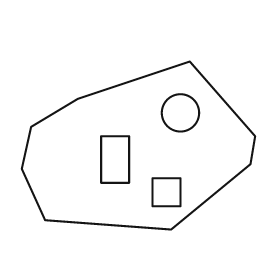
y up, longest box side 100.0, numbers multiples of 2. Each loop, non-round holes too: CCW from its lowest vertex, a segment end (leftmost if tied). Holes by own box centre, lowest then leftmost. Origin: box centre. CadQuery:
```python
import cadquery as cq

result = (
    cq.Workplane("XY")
    .moveTo(14.0, -36.0)
    .lineTo(48.0, -8.0)
    .lineTo(50.0, 4.0)
    .lineTo(22.0, 36.0)
    .lineTo(-26.0, 20.0)
    .lineTo(-46.0, 8.0)
    .lineTo(-50.0, -10.0)
    .lineTo(-40.0, -32.0)
    .close()
    .moveTo(6.0, -26.0)
    .lineTo(18.0, -26.0)
    .lineTo(18.0, -14.0)
    .lineTo(6.0, -14.0)
    .close()
    .moveTo(-16.0, -16.0)
    .lineTo(-4.0, -16.0)
    .lineTo(-4.0, 4.0)
    .lineTo(-16.0, 4.0)
    .close()
    .moveTo(18.0, 14.0)
    .circle(8.0)
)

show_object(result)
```